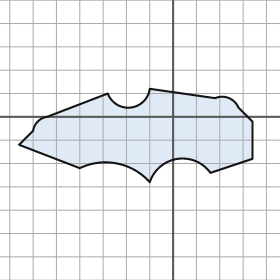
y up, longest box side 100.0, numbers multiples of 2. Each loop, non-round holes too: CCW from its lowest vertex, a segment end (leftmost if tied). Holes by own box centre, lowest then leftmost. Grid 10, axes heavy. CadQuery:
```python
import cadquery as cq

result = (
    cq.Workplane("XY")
    .moveTo(-10.0, -28.0)
    .threePointArc((2.0, -18.0), (16.0, -24.0))
    .lineTo(34.0, -18.0)
    .lineTo(34.0, -2.0)
    .lineTo(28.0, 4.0)
    .threePointArc((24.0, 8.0), (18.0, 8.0))
    .lineTo(-10.0, 12.0)
    .threePointArc((-18.0, 4.0), (-28.0, 10.0))
    .lineTo(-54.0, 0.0)
    .threePointArc((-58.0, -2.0), (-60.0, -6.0))
    .lineTo(-66.0, -12.0)
    .lineTo(-40.0, -22.0)
    .threePointArc((-24.0, -20.0), (-10.0, -28.0))
    .close()
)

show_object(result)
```